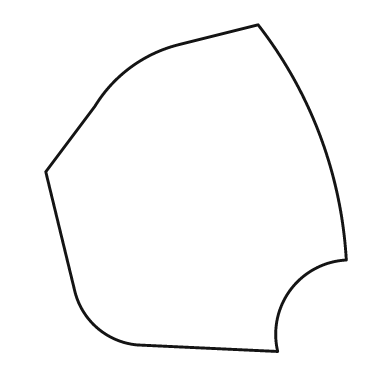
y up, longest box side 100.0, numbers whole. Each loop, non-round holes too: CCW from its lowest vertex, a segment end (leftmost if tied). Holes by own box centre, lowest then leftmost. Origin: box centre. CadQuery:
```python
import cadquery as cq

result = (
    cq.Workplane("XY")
    .moveTo(25.0, -50.0)
    .threePointArc((29.0, -31.0), (46.0, -22.0))
    .threePointArc((38.0, 16.0), (19.0, 50.0))
    .lineTo(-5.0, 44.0)
    .threePointArc((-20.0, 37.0), (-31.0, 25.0))
    .lineTo(-46.0, 5.0)
    .lineTo(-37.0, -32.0)
    .threePointArc((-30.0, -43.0), (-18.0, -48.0))
    .close()
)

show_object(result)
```